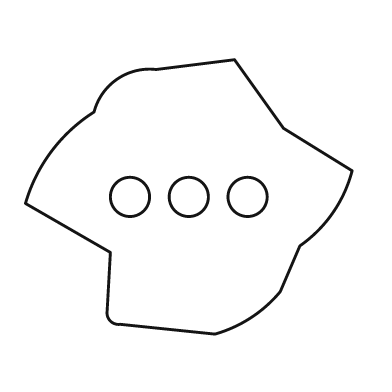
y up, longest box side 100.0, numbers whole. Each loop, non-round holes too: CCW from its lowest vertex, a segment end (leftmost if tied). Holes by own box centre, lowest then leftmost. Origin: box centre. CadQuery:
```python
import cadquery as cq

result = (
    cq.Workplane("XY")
    .moveTo(8.0, -42.0)
    .threePointArc((19.0, -37.0), (28.0, -29.0))
    .lineTo(34.0, -15.0)
    .threePointArc((44.0, -5.0), (50.0, 8.0))
    .lineTo(29.0, 21.0)
    .lineTo(14.0, 42.0)
    .lineTo(-10.0, 39.0)
    .threePointArc((-22.0, 36.0), (-29.0, 26.0))
    .threePointArc((-42.0, 14.0), (-50.0, -2.0))
    .lineTo(-24.0, -17.0)
    .lineTo(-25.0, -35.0)
    .threePointArc((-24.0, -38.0), (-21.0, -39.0))
    .close()
    .moveTo(-18.0, 0.0)
    .circle(6.0)
    .moveTo(0.0, 0.0)
    .circle(6.0)
    .moveTo(18.0, 0.0)
    .circle(6.0)
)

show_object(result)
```